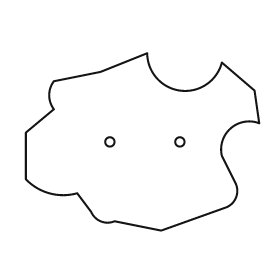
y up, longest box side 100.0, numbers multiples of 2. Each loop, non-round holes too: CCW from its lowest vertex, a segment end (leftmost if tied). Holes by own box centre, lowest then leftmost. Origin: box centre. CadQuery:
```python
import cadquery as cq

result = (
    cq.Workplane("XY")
    .moveTo(8.0, -38.0)
    .lineTo(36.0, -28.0)
    .threePointArc((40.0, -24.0), (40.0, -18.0))
    .lineTo(34.0, -6.0)
    .threePointArc((38.0, 6.0), (50.0, 8.0))
    .lineTo(48.0, 22.0)
    .lineTo(34.0, 34.0)
    .threePointArc((16.0, 22.0), (2.0, 38.0))
    .lineTo(-18.0, 30.0)
    .lineTo(-38.0, 26.0)
    .threePointArc((-40.0, 20.0), (-38.0, 14.0))
    .lineTo(-50.0, 4.0)
    .lineTo(-50.0, -16.0)
    .threePointArc((-40.0, -22.0), (-28.0, -22.0))
    .lineTo(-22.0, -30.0)
    .threePointArc((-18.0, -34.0), (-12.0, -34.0))
    .close()
    .moveTo(-14.0, 0.0)
    .circle(2.0)
    .moveTo(16.0, 0.0)
    .circle(2.0)
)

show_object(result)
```